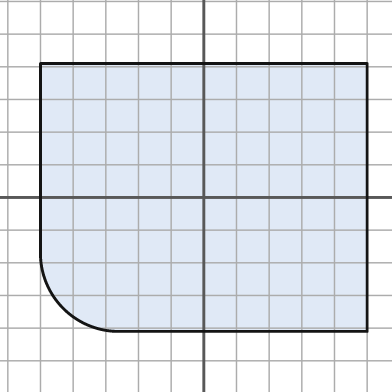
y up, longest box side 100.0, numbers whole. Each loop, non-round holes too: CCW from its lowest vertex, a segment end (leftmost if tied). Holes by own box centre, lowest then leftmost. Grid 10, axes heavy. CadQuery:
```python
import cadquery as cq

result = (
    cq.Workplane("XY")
    .moveTo(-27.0, -41.0)
    .lineTo(50.0, -41.0)
    .lineTo(50.0, 41.0)
    .lineTo(-50.0, 41.0)
    .lineTo(-50.0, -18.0)
    .threePointArc((-43.0, -34.0), (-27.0, -41.0))
    .close()
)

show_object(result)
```